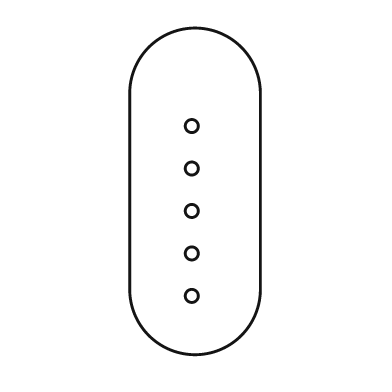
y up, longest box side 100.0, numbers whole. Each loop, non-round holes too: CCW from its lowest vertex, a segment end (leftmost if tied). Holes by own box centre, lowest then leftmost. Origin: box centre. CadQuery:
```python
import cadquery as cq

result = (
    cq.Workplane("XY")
    .moveTo(-20.0, -30.0)
    .threePointArc((0.0, -50.0), (20.0, -30.0))
    .lineTo(20.0, 30.0)
    .threePointArc((0.0, 50.0), (-20.0, 30.0))
    .close()
    .moveTo(-1.0, -32.0)
    .circle(2.0)
    .moveTo(-1.0, -19.0)
    .circle(2.0)
    .moveTo(-1.0, -6.0)
    .circle(2.0)
    .moveTo(-1.0, 7.0)
    .circle(2.0)
    .moveTo(-1.0, 20.0)
    .circle(2.0)
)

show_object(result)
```